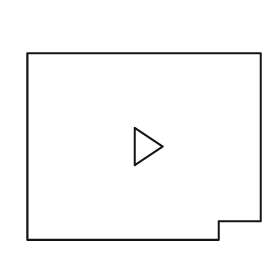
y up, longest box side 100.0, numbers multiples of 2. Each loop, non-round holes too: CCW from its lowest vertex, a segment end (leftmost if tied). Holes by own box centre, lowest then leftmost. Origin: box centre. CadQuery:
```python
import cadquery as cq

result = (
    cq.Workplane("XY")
    .moveTo(-50.0, -40.0)
    .lineTo(32.0, -40.0)
    .lineTo(32.0, -32.0)
    .lineTo(50.0, -32.0)
    .lineTo(50.0, 40.0)
    .lineTo(-50.0, 40.0)
    .close()
    .moveTo(-4.0, -8.0)
    .lineTo(8.0, 0.0)
    .lineTo(-4.0, 8.0)
    .close()
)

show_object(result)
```